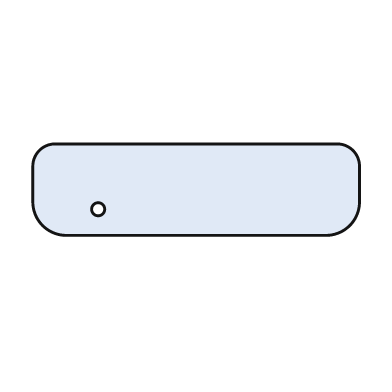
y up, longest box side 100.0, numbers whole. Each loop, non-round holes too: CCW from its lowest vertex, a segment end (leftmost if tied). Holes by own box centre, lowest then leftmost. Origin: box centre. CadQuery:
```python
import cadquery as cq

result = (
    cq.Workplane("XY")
    .moveTo(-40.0, -14.0)
    .lineTo(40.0, -14.0)
    .threePointArc((47.0, -11.0), (50.0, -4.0))
    .lineTo(50.0, 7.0)
    .threePointArc((48.0, 12.0), (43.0, 14.0))
    .lineTo(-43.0, 14.0)
    .threePointArc((-48.0, 12.0), (-50.0, 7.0))
    .lineTo(-50.0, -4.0)
    .threePointArc((-47.0, -11.0), (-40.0, -14.0))
    .close()
    .moveTo(-30.0, -6.0)
    .circle(2.0)
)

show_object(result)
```